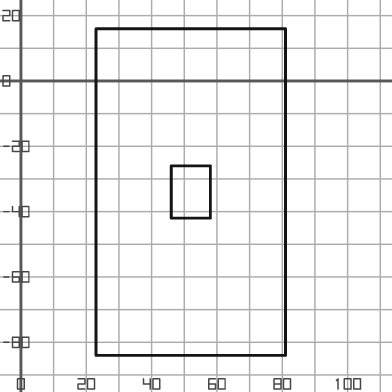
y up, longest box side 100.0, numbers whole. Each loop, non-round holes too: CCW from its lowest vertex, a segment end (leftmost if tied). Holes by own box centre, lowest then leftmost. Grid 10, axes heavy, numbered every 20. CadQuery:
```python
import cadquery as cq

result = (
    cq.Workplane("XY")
    .moveTo(23.0, -84.0)
    .lineTo(81.0, -84.0)
    .lineTo(81.0, 16.0)
    .lineTo(23.0, 16.0)
    .close()
    .moveTo(46.0, -42.0)
    .lineTo(58.0, -42.0)
    .lineTo(58.0, -26.0)
    .lineTo(46.0, -26.0)
    .close()
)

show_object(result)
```